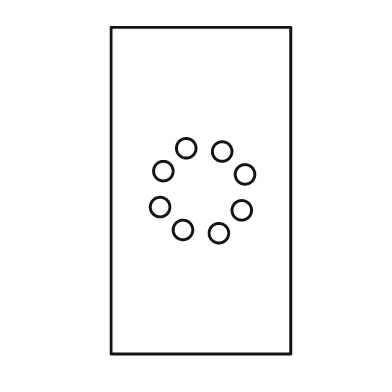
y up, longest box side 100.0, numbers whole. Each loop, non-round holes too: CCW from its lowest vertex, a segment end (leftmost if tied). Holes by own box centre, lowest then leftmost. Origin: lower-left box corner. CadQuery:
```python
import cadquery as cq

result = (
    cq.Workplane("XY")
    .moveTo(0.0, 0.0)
    .lineTo(55.0, 0.0)
    .lineTo(55.0, 100.0)
    .lineTo(0.0, 100.0)
    .close()
    .moveTo(33.0, 37.0)
    .circle(3.0)
    .moveTo(22.0, 38.0)
    .circle(3.0)
    .moveTo(40.0, 44.0)
    .circle(3.0)
    .moveTo(15.0, 45.0)
    .circle(3.0)
    .moveTo(41.0, 55.0)
    .circle(3.0)
    .moveTo(16.0, 56.0)
    .circle(3.0)
    .moveTo(34.0, 62.0)
    .circle(3.0)
    .moveTo(23.0, 63.0)
    .circle(3.0)
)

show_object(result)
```